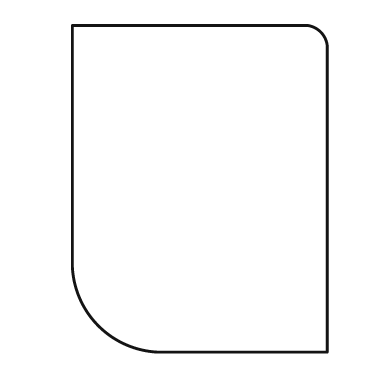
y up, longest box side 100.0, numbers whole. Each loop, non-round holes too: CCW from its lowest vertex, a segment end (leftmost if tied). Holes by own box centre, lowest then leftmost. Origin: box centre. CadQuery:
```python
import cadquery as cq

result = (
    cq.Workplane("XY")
    .moveTo(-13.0, -50.0)
    .lineTo(39.0, -50.0)
    .lineTo(39.0, 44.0)
    .threePointArc((37.0, 48.0), (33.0, 50.0))
    .lineTo(-39.0, 50.0)
    .lineTo(-39.0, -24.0)
    .threePointArc((-31.0, -42.0), (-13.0, -50.0))
    .close()
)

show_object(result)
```